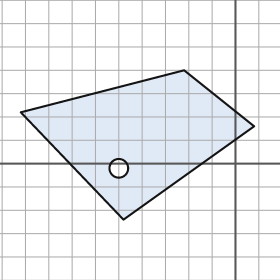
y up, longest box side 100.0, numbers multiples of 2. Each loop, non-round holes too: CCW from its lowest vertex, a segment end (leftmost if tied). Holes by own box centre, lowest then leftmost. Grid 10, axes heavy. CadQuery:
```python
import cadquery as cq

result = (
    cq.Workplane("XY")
    .moveTo(-48.0, -24.0)
    .lineTo(8.0, 16.0)
    .lineTo(-22.0, 40.0)
    .lineTo(-92.0, 22.0)
    .close()
    .moveTo(-50.0, -2.0)
    .circle(4.0)
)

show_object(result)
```